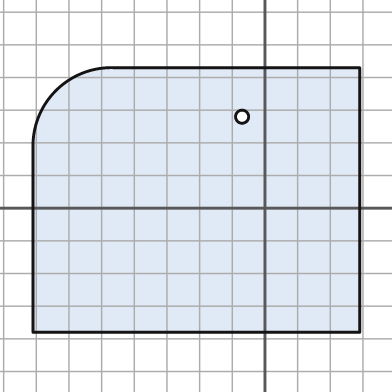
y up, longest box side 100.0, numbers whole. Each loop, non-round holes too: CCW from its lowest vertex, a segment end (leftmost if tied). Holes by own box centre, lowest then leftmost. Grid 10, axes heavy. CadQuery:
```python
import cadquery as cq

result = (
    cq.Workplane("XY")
    .moveTo(-71.0, -38.0)
    .lineTo(29.0, -38.0)
    .lineTo(29.0, 43.0)
    .lineTo(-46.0, 43.0)
    .threePointArc((-64.0, 36.0), (-71.0, 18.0))
    .close()
    .moveTo(-7.0, 28.0)
    .circle(2.0)
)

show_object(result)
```